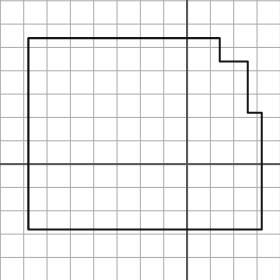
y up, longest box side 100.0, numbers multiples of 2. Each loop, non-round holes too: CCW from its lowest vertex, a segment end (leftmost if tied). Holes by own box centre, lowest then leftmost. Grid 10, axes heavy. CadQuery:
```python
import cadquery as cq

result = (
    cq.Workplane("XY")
    .moveTo(-68.0, -28.0)
    .lineTo(32.0, -28.0)
    .lineTo(32.0, 22.0)
    .lineTo(26.0, 22.0)
    .lineTo(26.0, 44.0)
    .lineTo(14.0, 44.0)
    .lineTo(14.0, 54.0)
    .lineTo(-68.0, 54.0)
    .close()
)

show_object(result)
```